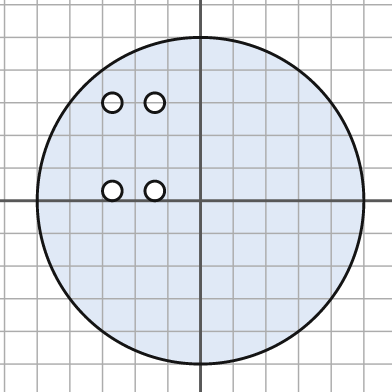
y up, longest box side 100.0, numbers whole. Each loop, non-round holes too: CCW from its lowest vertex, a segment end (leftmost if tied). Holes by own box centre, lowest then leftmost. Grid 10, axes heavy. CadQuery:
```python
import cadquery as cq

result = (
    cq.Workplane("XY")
    .moveTo(0.0, 0.0)
    .circle(50.0)
    .moveTo(-27.0, 3.0)
    .circle(3.0)
    .moveTo(-14.0, 3.0)
    .circle(3.0)
    .moveTo(-27.0, 30.0)
    .circle(3.0)
    .moveTo(-14.0, 30.0)
    .circle(3.0)
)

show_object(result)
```